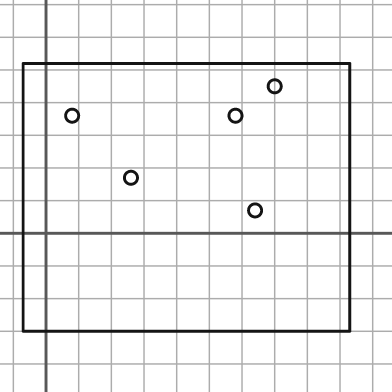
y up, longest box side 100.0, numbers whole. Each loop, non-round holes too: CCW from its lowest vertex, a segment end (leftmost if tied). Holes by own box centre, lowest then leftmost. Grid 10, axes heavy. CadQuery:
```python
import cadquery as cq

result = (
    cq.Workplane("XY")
    .moveTo(-7.0, -30.0)
    .lineTo(93.0, -30.0)
    .lineTo(93.0, 52.0)
    .lineTo(-7.0, 52.0)
    .close()
    .moveTo(64.0, 7.0)
    .circle(2.0)
    .moveTo(26.0, 17.0)
    .circle(2.0)
    .moveTo(8.0, 36.0)
    .circle(2.0)
    .moveTo(58.0, 36.0)
    .circle(2.0)
    .moveTo(70.0, 45.0)
    .circle(2.0)
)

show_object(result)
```